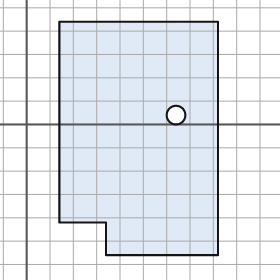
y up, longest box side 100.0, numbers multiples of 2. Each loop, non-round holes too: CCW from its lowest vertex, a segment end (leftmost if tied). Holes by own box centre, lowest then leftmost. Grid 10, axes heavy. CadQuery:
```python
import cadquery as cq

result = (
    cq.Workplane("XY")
    .moveTo(34.0, -56.0)
    .lineTo(82.0, -56.0)
    .lineTo(82.0, 44.0)
    .lineTo(14.0, 44.0)
    .lineTo(14.0, -42.0)
    .lineTo(34.0, -42.0)
    .close()
    .moveTo(64.0, 4.0)
    .circle(4.0)
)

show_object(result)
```